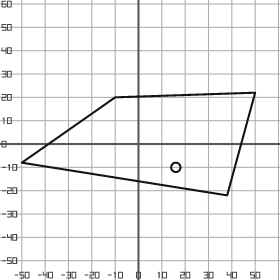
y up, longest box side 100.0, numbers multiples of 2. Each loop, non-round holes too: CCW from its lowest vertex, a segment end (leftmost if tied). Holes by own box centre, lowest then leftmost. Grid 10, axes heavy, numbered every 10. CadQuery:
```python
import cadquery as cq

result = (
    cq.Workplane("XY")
    .moveTo(38.0, -22.0)
    .lineTo(50.0, 22.0)
    .lineTo(-10.0, 20.0)
    .lineTo(-50.0, -8.0)
    .close()
    .moveTo(16.0, -10.0)
    .circle(2.0)
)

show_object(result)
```